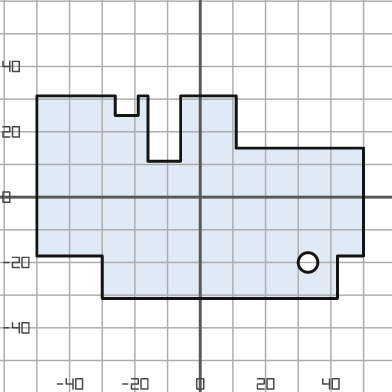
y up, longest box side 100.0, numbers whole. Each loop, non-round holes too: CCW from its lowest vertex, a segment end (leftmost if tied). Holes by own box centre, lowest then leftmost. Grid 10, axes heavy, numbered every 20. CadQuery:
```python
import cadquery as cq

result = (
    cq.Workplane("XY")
    .moveTo(-30.0, -31.0)
    .lineTo(42.0, -31.0)
    .lineTo(42.0, -18.0)
    .lineTo(50.0, -18.0)
    .lineTo(50.0, 15.0)
    .lineTo(11.0, 15.0)
    .lineTo(11.0, 31.0)
    .lineTo(-6.0, 31.0)
    .lineTo(-6.0, 11.0)
    .lineTo(-16.0, 11.0)
    .lineTo(-16.0, 31.0)
    .lineTo(-19.0, 31.0)
    .lineTo(-19.0, 25.0)
    .lineTo(-26.0, 25.0)
    .lineTo(-26.0, 31.0)
    .lineTo(-50.0, 31.0)
    .lineTo(-50.0, -18.0)
    .lineTo(-30.0, -18.0)
    .close()
    .moveTo(33.0, -20.0)
    .circle(3.0)
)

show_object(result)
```